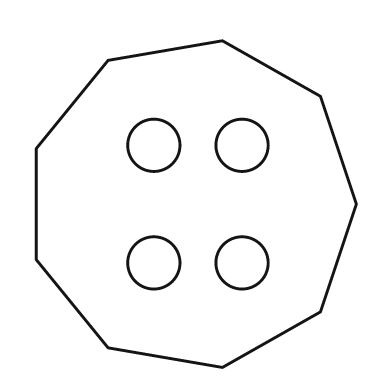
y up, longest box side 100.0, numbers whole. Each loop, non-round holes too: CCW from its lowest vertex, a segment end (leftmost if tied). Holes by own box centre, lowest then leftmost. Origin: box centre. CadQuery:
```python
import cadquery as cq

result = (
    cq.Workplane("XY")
    .moveTo(8.0, -50.0)
    .lineTo(38.0, -33.0)
    .lineTo(49.0, 0.0)
    .lineTo(38.0, 33.0)
    .lineTo(8.0, 50.0)
    .lineTo(-27.0, 44.0)
    .lineTo(-49.0, 17.0)
    .lineTo(-49.0, -17.0)
    .lineTo(-27.0, -44.0)
    .close()
    .moveTo(-13.0, -18.0)
    .circle(8.0)
    .moveTo(14.0, -18.0)
    .circle(8.0)
    .moveTo(-13.0, 18.0)
    .circle(8.0)
    .moveTo(14.0, 18.0)
    .circle(8.0)
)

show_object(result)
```